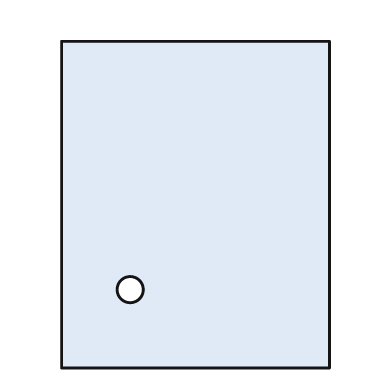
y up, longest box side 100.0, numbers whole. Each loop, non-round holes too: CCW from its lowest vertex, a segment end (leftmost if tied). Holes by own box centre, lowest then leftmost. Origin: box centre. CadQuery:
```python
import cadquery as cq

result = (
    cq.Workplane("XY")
    .moveTo(-41.0, -50.0)
    .lineTo(41.0, -50.0)
    .lineTo(41.0, 50.0)
    .lineTo(-41.0, 50.0)
    .close()
    .moveTo(-20.0, -26.0)
    .circle(4.0)
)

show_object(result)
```